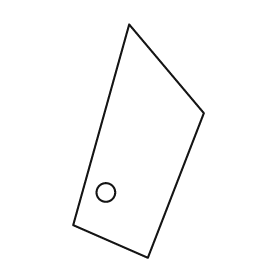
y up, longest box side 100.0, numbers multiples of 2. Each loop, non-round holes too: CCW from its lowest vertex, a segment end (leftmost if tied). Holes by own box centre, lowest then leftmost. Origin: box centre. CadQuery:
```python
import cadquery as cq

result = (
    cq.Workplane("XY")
    .moveTo(4.0, -50.0)
    .lineTo(28.0, 12.0)
    .lineTo(-4.0, 50.0)
    .lineTo(-28.0, -36.0)
    .close()
    .moveTo(-14.0, -22.0)
    .circle(4.0)
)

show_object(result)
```